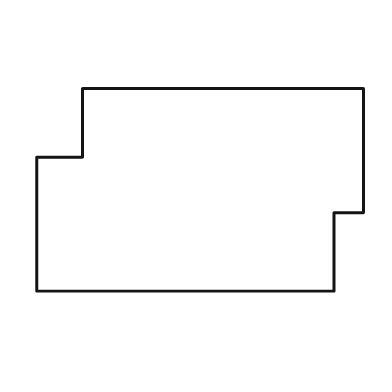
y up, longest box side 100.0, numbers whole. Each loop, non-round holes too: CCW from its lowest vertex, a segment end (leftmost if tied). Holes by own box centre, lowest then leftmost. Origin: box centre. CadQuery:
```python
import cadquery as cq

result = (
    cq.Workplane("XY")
    .moveTo(-50.0, -31.0)
    .lineTo(41.0, -31.0)
    .lineTo(41.0, -7.0)
    .lineTo(50.0, -7.0)
    .lineTo(50.0, 31.0)
    .lineTo(-36.0, 31.0)
    .lineTo(-36.0, 10.0)
    .lineTo(-50.0, 10.0)
    .close()
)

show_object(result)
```